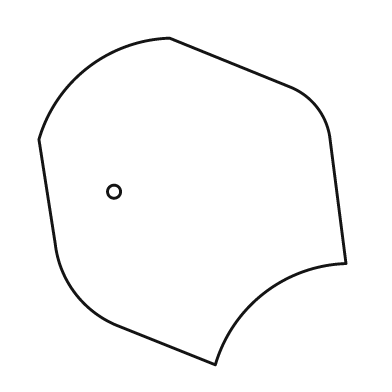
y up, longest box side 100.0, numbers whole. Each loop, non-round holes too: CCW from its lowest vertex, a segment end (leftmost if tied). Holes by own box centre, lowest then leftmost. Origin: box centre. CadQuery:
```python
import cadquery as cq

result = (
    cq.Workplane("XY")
    .moveTo(7.0, -50.0)
    .threePointArc((22.0, -28.0), (47.0, -19.0))
    .lineTo(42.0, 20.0)
    .threePointArc((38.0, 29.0), (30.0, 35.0))
    .lineTo(-7.0, 50.0)
    .threePointArc((-32.0, 41.0), (-47.0, 19.0))
    .lineTo(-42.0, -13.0)
    .threePointArc((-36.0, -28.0), (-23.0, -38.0))
    .close()
    .moveTo(-24.0, 3.0)
    .circle(2.0)
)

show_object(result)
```